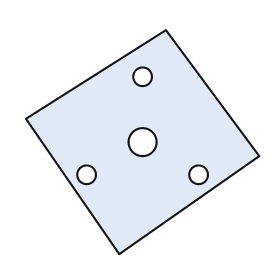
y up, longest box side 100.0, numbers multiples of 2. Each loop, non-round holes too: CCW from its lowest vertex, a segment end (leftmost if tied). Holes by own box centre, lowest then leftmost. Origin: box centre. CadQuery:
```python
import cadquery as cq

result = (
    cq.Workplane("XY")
    .moveTo(-10.0, -48.0)
    .lineTo(50.0, -6.0)
    .lineTo(10.0, 48.0)
    .lineTo(-50.0, 10.0)
    .close()
    .moveTo(-24.0, -14.0)
    .circle(4.0)
    .moveTo(24.0, -14.0)
    .circle(4.0)
    .moveTo(0.0, 0.0)
    .circle(6.0)
    .moveTo(0.0, 28.0)
    .circle(4.0)
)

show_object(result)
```